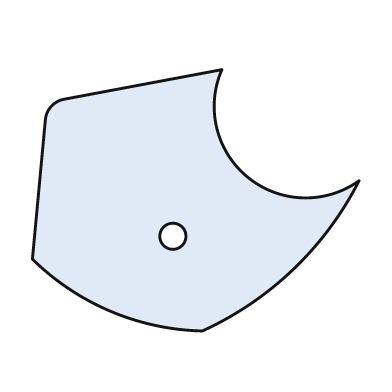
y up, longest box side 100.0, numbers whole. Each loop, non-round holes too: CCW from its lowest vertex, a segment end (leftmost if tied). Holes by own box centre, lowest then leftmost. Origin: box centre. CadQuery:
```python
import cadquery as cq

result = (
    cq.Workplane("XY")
    .moveTo(2.0, -40.0)
    .threePointArc((30.0, -21.0), (50.0, 6.0))
    .threePointArc((16.0, 7.0), (8.0, 40.0))
    .lineTo(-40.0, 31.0)
    .threePointArc((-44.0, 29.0), (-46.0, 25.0))
    .lineTo(-50.0, -18.0)
    .threePointArc((-26.0, -34.0), (2.0, -40.0))
    .close()
    .moveTo(-7.0, -11.0)
    .circle(4.0)
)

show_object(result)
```